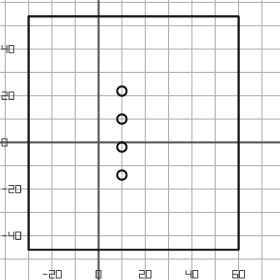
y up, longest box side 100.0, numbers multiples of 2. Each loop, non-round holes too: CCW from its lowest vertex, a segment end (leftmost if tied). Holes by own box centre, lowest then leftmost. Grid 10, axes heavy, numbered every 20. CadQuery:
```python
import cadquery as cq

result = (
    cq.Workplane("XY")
    .moveTo(-30.0, -46.0)
    .lineTo(60.0, -46.0)
    .lineTo(60.0, 54.0)
    .lineTo(-30.0, 54.0)
    .close()
    .moveTo(10.0, -14.0)
    .circle(2.0)
    .moveTo(10.0, -2.0)
    .circle(2.0)
    .moveTo(10.0, 10.0)
    .circle(2.0)
    .moveTo(10.0, 22.0)
    .circle(2.0)
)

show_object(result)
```